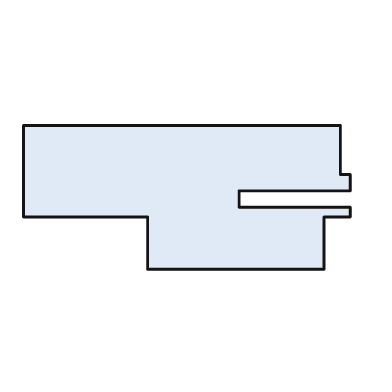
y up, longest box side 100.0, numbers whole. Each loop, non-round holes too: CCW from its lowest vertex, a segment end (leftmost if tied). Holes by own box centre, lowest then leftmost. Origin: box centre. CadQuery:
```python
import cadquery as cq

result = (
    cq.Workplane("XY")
    .moveTo(-12.0, -22.0)
    .lineTo(42.0, -22.0)
    .lineTo(42.0, -6.0)
    .lineTo(50.0, -6.0)
    .lineTo(50.0, -3.0)
    .lineTo(16.0, -3.0)
    .lineTo(16.0, 2.0)
    .lineTo(50.0, 2.0)
    .lineTo(50.0, 7.0)
    .lineTo(47.0, 7.0)
    .lineTo(47.0, 22.0)
    .lineTo(-50.0, 22.0)
    .lineTo(-50.0, -6.0)
    .lineTo(-12.0, -6.0)
    .close()
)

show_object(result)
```